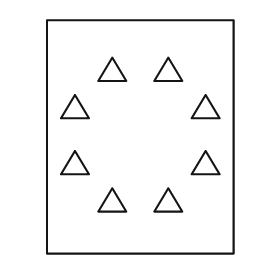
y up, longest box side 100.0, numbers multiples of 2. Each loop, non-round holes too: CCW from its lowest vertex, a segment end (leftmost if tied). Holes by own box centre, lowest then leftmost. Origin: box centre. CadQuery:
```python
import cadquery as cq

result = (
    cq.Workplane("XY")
    .moveTo(-40.0, -50.0)
    .lineTo(40.0, -50.0)
    .lineTo(40.0, 50.0)
    .lineTo(-40.0, 50.0)
    .close()
    .moveTo(-18.0, -32.0)
    .lineTo(-6.0, -32.0)
    .lineTo(-12.0, -22.0)
    .close()
    .moveTo(6.0, -32.0)
    .lineTo(18.0, -32.0)
    .lineTo(12.0, -22.0)
    .close()
    .moveTo(-34.0, -16.0)
    .lineTo(-22.0, -16.0)
    .lineTo(-28.0, -6.0)
    .close()
    .moveTo(22.0, -16.0)
    .lineTo(34.0, -16.0)
    .lineTo(28.0, -6.0)
    .close()
    .moveTo(-34.0, 8.0)
    .lineTo(-22.0, 8.0)
    .lineTo(-28.0, 18.0)
    .close()
    .moveTo(22.0, 8.0)
    .lineTo(34.0, 8.0)
    .lineTo(28.0, 18.0)
    .close()
    .moveTo(-18.0, 24.0)
    .lineTo(-6.0, 24.0)
    .lineTo(-12.0, 34.0)
    .close()
    .moveTo(6.0, 24.0)
    .lineTo(18.0, 24.0)
    .lineTo(12.0, 34.0)
    .close()
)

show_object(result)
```